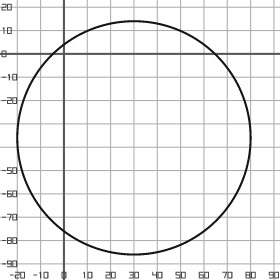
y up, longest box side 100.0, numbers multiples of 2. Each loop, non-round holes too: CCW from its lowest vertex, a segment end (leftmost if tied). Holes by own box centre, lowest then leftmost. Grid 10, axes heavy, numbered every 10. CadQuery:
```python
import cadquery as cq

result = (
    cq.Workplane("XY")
    .moveTo(30.0, -36.0)
    .circle(50.0)
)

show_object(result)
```